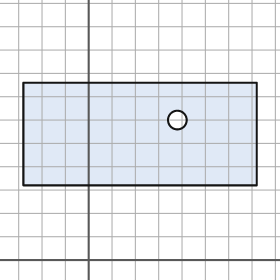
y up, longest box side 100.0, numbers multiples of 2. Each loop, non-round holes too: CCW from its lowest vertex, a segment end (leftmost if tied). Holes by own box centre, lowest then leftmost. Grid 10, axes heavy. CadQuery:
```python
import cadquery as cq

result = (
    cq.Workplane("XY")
    .moveTo(-28.0, 32.0)
    .lineTo(72.0, 32.0)
    .lineTo(72.0, 76.0)
    .lineTo(-28.0, 76.0)
    .close()
    .moveTo(38.0, 60.0)
    .circle(4.0)
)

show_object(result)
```